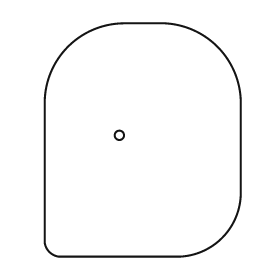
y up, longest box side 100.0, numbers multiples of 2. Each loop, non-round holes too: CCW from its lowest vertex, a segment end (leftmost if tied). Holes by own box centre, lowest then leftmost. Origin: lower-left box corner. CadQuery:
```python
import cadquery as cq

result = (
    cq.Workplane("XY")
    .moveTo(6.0, 0.0)
    .lineTo(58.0, 0.0)
    .threePointArc((76.0, 8.0), (84.0, 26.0))
    .lineTo(84.0, 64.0)
    .threePointArc((74.0, 90.0), (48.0, 100.0))
    .lineTo(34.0, 100.0)
    .threePointArc((10.0, 90.0), (0.0, 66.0))
    .lineTo(0.0, 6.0)
    .threePointArc((2.0, 2.0), (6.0, 0.0))
    .close()
    .moveTo(32.0, 52.0)
    .circle(2.0)
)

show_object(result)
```